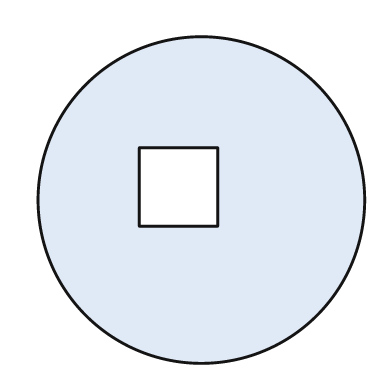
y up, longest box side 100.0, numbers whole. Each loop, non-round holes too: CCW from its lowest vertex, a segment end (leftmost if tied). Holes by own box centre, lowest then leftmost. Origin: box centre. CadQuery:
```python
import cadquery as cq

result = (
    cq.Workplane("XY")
    .moveTo(0.0, 0.0)
    .circle(50.0)
    .moveTo(-19.0, -8.0)
    .lineTo(5.0, -8.0)
    .lineTo(5.0, 16.0)
    .lineTo(-19.0, 16.0)
    .close()
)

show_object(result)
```